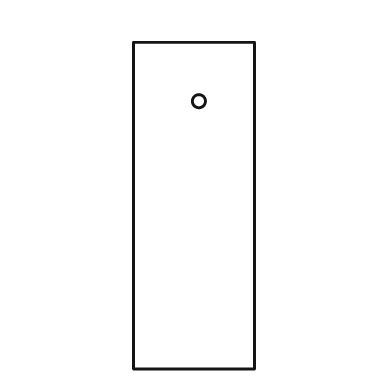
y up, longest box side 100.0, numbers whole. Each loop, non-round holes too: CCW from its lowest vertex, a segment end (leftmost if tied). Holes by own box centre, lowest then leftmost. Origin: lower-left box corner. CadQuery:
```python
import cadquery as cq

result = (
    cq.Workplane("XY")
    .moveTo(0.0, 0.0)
    .lineTo(37.0, 0.0)
    .lineTo(37.0, 100.0)
    .lineTo(0.0, 100.0)
    .close()
    .moveTo(20.0, 82.0)
    .circle(2.0)
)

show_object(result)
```